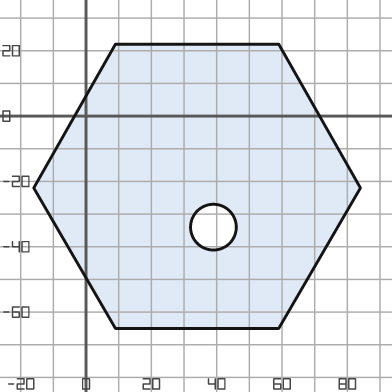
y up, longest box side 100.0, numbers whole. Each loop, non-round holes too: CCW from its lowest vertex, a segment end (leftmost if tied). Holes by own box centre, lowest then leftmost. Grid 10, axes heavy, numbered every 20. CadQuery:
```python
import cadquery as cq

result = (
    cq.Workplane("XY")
    .moveTo(9.0, -65.0)
    .lineTo(59.0, -65.0)
    .lineTo(84.0, -22.0)
    .lineTo(59.0, 22.0)
    .lineTo(9.0, 22.0)
    .lineTo(-16.0, -22.0)
    .close()
    .moveTo(39.0, -34.0)
    .circle(7.0)
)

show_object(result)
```